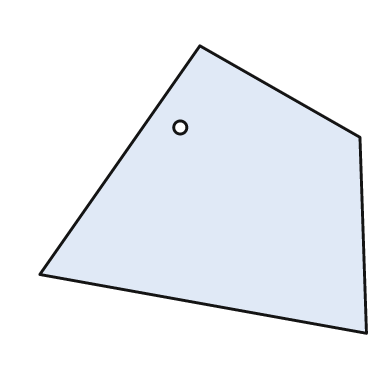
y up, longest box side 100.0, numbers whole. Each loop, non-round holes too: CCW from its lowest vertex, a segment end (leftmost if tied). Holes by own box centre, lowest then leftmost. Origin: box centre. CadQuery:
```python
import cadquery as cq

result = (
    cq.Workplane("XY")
    .moveTo(50.0, -44.0)
    .lineTo(48.0, 16.0)
    .lineTo(-1.0, 44.0)
    .lineTo(-50.0, -26.0)
    .close()
    .moveTo(-7.0, 19.0)
    .circle(2.0)
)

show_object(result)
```